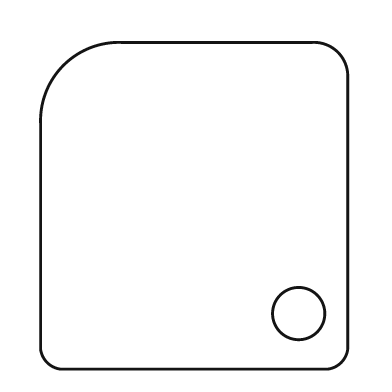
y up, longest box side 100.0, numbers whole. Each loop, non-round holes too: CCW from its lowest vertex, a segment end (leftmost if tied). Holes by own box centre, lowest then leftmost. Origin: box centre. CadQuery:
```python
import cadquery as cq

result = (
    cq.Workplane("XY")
    .moveTo(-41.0, -50.0)
    .lineTo(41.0, -50.0)
    .threePointArc((45.0, -48.0), (47.0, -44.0))
    .lineTo(47.0, 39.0)
    .threePointArc((44.0, 47.0), (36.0, 50.0))
    .lineTo(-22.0, 50.0)
    .threePointArc((-40.0, 43.0), (-47.0, 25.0))
    .lineTo(-47.0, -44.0)
    .threePointArc((-45.0, -48.0), (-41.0, -50.0))
    .close()
    .moveTo(32.0, -33.0)
    .circle(8.0)
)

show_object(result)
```